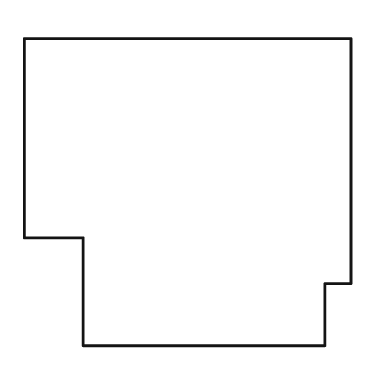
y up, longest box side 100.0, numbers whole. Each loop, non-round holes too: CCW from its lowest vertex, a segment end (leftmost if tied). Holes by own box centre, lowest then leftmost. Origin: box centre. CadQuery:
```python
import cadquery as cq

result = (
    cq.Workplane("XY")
    .moveTo(-32.0, -47.0)
    .lineTo(42.0, -47.0)
    .lineTo(42.0, -28.0)
    .lineTo(50.0, -28.0)
    .lineTo(50.0, 47.0)
    .lineTo(-50.0, 47.0)
    .lineTo(-50.0, -14.0)
    .lineTo(-32.0, -14.0)
    .close()
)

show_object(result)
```